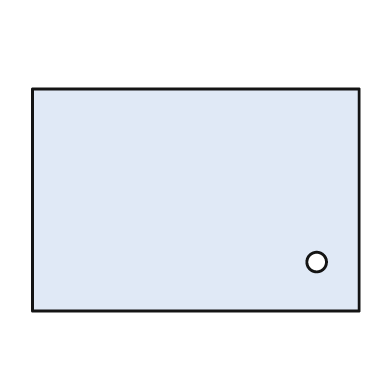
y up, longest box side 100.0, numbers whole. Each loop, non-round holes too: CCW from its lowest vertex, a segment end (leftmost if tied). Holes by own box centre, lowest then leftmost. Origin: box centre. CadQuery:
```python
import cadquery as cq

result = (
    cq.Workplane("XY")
    .moveTo(-50.0, -34.0)
    .lineTo(50.0, -34.0)
    .lineTo(50.0, 34.0)
    .lineTo(-50.0, 34.0)
    .close()
    .moveTo(37.0, -19.0)
    .circle(3.0)
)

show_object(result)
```